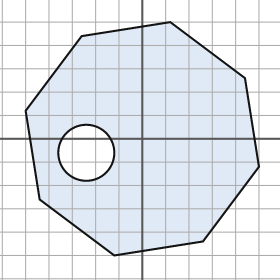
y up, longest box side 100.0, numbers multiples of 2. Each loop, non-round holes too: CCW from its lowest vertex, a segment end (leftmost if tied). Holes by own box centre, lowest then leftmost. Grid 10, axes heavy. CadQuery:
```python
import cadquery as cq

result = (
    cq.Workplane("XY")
    .moveTo(-12.0, -50.0)
    .lineTo(26.0, -44.0)
    .lineTo(50.0, -12.0)
    .lineTo(44.0, 26.0)
    .lineTo(12.0, 50.0)
    .lineTo(-26.0, 44.0)
    .lineTo(-50.0, 12.0)
    .lineTo(-44.0, -26.0)
    .close()
    .moveTo(-24.0, -6.0)
    .circle(12.0)
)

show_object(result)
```